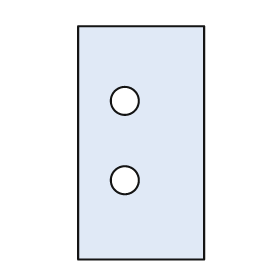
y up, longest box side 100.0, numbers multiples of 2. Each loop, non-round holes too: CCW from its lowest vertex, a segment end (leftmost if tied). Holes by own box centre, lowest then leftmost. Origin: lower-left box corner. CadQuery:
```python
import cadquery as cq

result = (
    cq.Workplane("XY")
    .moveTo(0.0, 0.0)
    .lineTo(54.0, 0.0)
    .lineTo(54.0, 100.0)
    .lineTo(0.0, 100.0)
    .close()
    .moveTo(20.0, 34.0)
    .circle(6.0)
    .moveTo(20.0, 68.0)
    .circle(6.0)
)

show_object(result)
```